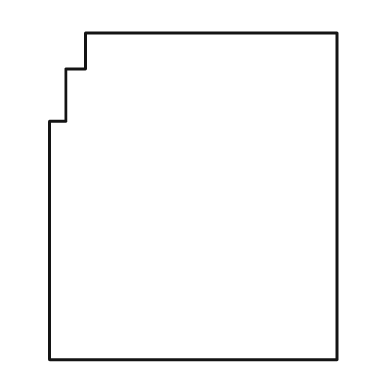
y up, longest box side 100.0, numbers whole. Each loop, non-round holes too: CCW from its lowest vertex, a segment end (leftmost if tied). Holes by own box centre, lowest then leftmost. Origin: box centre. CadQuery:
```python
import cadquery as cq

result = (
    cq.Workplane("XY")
    .moveTo(-44.0, -50.0)
    .lineTo(44.0, -50.0)
    .lineTo(44.0, 50.0)
    .lineTo(-33.0, 50.0)
    .lineTo(-33.0, 39.0)
    .lineTo(-39.0, 39.0)
    .lineTo(-39.0, 23.0)
    .lineTo(-44.0, 23.0)
    .close()
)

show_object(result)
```